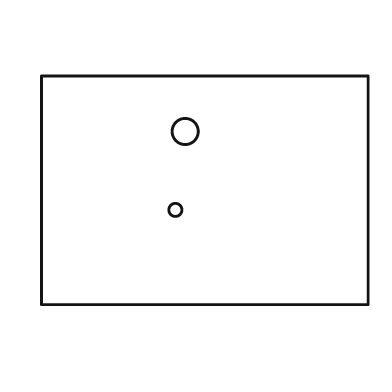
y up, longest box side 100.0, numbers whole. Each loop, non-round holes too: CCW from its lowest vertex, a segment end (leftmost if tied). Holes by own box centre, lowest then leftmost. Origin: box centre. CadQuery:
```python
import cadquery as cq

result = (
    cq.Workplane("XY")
    .moveTo(-50.0, -35.0)
    .lineTo(50.0, -35.0)
    .lineTo(50.0, 35.0)
    .lineTo(-50.0, 35.0)
    .close()
    .moveTo(-9.0, -6.0)
    .circle(2.0)
    .moveTo(-6.0, 18.0)
    .circle(4.0)
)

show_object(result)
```